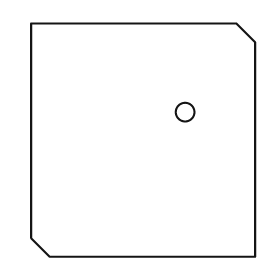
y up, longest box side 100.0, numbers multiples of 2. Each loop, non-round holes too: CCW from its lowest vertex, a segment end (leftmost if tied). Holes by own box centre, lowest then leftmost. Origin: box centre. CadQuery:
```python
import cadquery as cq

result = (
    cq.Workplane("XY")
    .moveTo(-40.0, -50.0)
    .lineTo(48.0, -50.0)
    .lineTo(48.0, 42.0)
    .lineTo(40.0, 50.0)
    .lineTo(-48.0, 50.0)
    .lineTo(-48.0, -42.0)
    .close()
    .moveTo(18.0, 12.0)
    .circle(4.0)
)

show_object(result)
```